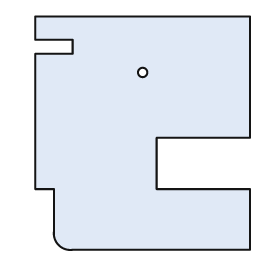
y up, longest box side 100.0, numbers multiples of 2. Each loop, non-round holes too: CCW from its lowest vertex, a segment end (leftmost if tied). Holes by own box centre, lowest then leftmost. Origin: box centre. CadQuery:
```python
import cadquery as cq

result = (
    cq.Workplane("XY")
    .moveTo(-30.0, -50.0)
    .lineTo(46.0, -50.0)
    .lineTo(46.0, -24.0)
    .lineTo(6.0, -24.0)
    .lineTo(6.0, -2.0)
    .lineTo(46.0, -2.0)
    .lineTo(46.0, 50.0)
    .lineTo(-46.0, 50.0)
    .lineTo(-46.0, 40.0)
    .lineTo(-30.0, 40.0)
    .lineTo(-30.0, 34.0)
    .lineTo(-46.0, 34.0)
    .lineTo(-46.0, -24.0)
    .lineTo(-38.0, -24.0)
    .lineTo(-38.0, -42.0)
    .threePointArc((-36.0, -48.0), (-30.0, -50.0))
    .close()
    .moveTo(0.0, 26.0)
    .circle(2.0)
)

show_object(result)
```